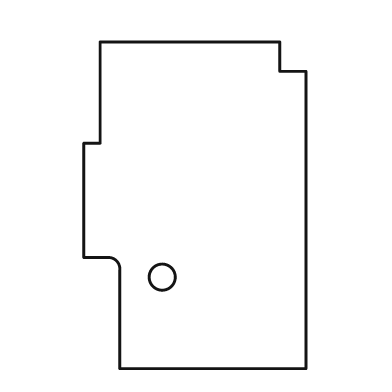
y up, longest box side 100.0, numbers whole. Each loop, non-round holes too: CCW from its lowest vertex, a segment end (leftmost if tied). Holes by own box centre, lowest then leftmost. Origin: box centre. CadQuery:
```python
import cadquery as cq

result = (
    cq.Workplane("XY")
    .moveTo(-23.0, -50.0)
    .lineTo(34.0, -50.0)
    .lineTo(34.0, 41.0)
    .lineTo(26.0, 41.0)
    .lineTo(26.0, 50.0)
    .lineTo(-29.0, 50.0)
    .lineTo(-29.0, 19.0)
    .lineTo(-34.0, 19.0)
    .lineTo(-34.0, -16.0)
    .lineTo(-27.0, -16.0)
    .threePointArc((-24.0, -17.0), (-23.0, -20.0))
    .close()
    .moveTo(-10.0, -22.0)
    .circle(4.0)
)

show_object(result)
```